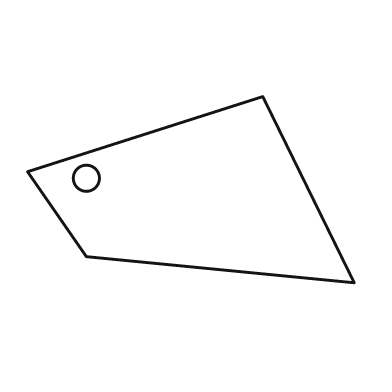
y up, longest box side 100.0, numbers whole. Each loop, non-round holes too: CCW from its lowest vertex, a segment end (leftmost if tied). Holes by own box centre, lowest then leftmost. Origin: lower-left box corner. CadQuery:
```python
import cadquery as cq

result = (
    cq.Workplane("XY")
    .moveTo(100.0, 0.0)
    .lineTo(72.0, 57.0)
    .lineTo(0.0, 34.0)
    .lineTo(18.0, 8.0)
    .close()
    .moveTo(18.0, 32.0)
    .circle(4.0)
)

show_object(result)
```